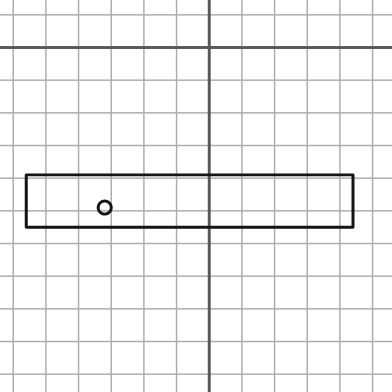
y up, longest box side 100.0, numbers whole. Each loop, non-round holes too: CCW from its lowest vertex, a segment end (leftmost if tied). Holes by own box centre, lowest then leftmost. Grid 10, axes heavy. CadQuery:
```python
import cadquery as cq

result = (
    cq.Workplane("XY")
    .moveTo(-56.0, -55.0)
    .lineTo(44.0, -55.0)
    .lineTo(44.0, -39.0)
    .lineTo(-56.0, -39.0)
    .close()
    .moveTo(-32.0, -49.0)
    .circle(2.0)
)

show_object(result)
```